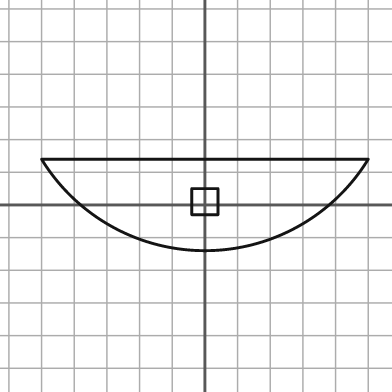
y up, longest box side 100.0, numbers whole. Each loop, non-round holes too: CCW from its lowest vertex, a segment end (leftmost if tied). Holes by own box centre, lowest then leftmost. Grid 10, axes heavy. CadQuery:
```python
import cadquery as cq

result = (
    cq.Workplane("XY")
    .moveTo(-50.0, 14.0)
    .threePointArc((0.0, -14.0), (50.0, 14.0))
    .close()
    .moveTo(-4.0, -3.0)
    .lineTo(4.0, -3.0)
    .lineTo(4.0, 5.0)
    .lineTo(-4.0, 5.0)
    .close()
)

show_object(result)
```